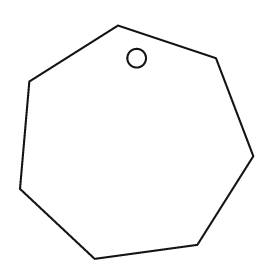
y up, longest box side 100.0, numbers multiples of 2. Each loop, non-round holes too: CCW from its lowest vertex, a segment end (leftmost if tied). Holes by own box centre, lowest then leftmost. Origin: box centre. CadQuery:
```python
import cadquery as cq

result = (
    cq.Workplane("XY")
    .moveTo(-18.0, -50.0)
    .lineTo(26.0, -44.0)
    .lineTo(50.0, -6.0)
    .lineTo(34.0, 36.0)
    .lineTo(-8.0, 50.0)
    .lineTo(-46.0, 26.0)
    .lineTo(-50.0, -20.0)
    .close()
    .moveTo(0.0, 36.0)
    .circle(4.0)
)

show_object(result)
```